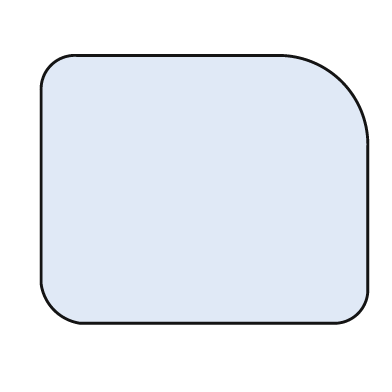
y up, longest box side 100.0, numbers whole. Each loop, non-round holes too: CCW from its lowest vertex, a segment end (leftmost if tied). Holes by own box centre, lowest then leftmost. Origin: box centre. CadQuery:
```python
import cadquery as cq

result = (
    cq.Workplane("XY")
    .moveTo(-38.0, -41.0)
    .lineTo(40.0, -41.0)
    .threePointArc((47.0, -38.0), (50.0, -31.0))
    .lineTo(50.0, 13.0)
    .threePointArc((42.0, 33.0), (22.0, 41.0))
    .lineTo(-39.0, 41.0)
    .threePointArc((-47.0, 38.0), (-50.0, 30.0))
    .lineTo(-50.0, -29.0)
    .threePointArc((-46.0, -37.0), (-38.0, -41.0))
    .close()
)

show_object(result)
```